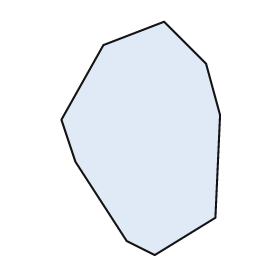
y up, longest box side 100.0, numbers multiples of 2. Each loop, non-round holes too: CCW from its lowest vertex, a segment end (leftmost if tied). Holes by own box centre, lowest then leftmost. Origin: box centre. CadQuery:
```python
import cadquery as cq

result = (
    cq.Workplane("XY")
    .moveTo(6.0, -50.0)
    .lineTo(32.0, -34.0)
    .lineTo(34.0, 10.0)
    .lineTo(28.0, 32.0)
    .lineTo(10.0, 50.0)
    .lineTo(-16.0, 40.0)
    .lineTo(-34.0, 8.0)
    .lineTo(-28.0, -10.0)
    .lineTo(-6.0, -44.0)
    .close()
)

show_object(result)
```